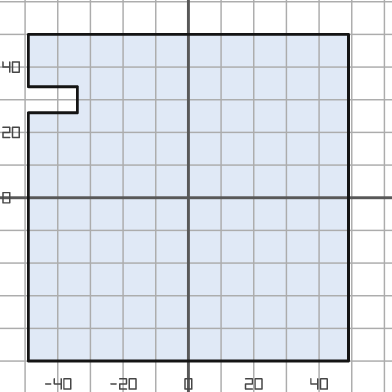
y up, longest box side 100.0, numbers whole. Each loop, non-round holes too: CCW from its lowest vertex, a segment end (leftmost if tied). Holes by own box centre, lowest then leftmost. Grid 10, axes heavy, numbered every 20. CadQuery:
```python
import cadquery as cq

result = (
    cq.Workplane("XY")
    .moveTo(-49.0, -50.0)
    .lineTo(49.0, -50.0)
    .lineTo(49.0, 50.0)
    .lineTo(-49.0, 50.0)
    .lineTo(-49.0, 34.0)
    .lineTo(-34.0, 34.0)
    .lineTo(-34.0, 26.0)
    .lineTo(-49.0, 26.0)
    .close()
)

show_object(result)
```